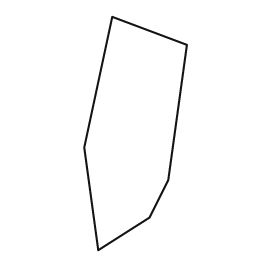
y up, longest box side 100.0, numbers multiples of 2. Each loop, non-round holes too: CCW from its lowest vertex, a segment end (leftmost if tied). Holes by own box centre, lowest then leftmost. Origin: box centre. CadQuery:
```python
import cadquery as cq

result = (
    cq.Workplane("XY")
    .moveTo(-16.0, -50.0)
    .lineTo(6.0, -36.0)
    .lineTo(14.0, -20.0)
    .lineTo(22.0, 38.0)
    .lineTo(-10.0, 50.0)
    .lineTo(-22.0, -6.0)
    .close()
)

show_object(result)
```